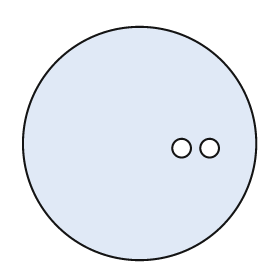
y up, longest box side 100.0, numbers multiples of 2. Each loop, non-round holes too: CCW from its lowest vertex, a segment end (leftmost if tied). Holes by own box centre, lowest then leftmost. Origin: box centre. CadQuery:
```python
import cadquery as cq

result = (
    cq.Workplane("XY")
    .moveTo(0.0, 0.0)
    .circle(50.0)
    .moveTo(18.0, -2.0)
    .circle(4.0)
    .moveTo(30.0, -2.0)
    .circle(4.0)
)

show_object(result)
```